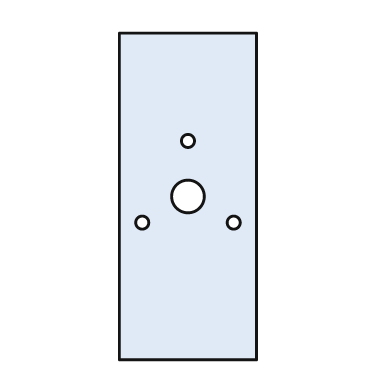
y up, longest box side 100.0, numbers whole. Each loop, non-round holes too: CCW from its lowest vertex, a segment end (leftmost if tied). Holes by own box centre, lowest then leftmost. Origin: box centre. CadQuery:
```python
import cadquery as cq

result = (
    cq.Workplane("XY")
    .moveTo(-21.0, -50.0)
    .lineTo(21.0, -50.0)
    .lineTo(21.0, 50.0)
    .lineTo(-21.0, 50.0)
    .close()
    .moveTo(-14.0, -8.0)
    .circle(2.0)
    .moveTo(14.0, -8.0)
    .circle(2.0)
    .moveTo(0.0, 0.0)
    .circle(5.0)
    .moveTo(0.0, 17.0)
    .circle(2.0)
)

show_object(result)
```